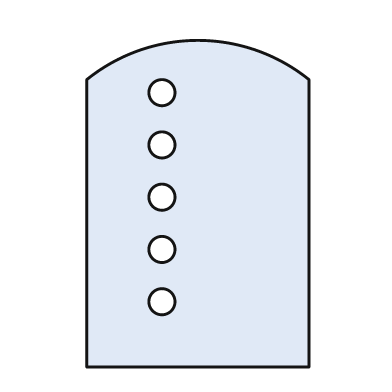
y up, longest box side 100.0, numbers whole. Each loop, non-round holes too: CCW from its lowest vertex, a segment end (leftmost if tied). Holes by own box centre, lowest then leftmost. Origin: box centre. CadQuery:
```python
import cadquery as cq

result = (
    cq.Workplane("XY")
    .moveTo(-34.0, -50.0)
    .lineTo(34.0, -50.0)
    .lineTo(34.0, 38.0)
    .threePointArc((0.0, 50.0), (-34.0, 38.0))
    .close()
    .moveTo(-11.0, -30.0)
    .circle(4.0)
    .moveTo(-11.0, -14.0)
    .circle(4.0)
    .moveTo(-11.0, 2.0)
    .circle(4.0)
    .moveTo(-11.0, 18.0)
    .circle(4.0)
    .moveTo(-11.0, 34.0)
    .circle(4.0)
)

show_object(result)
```